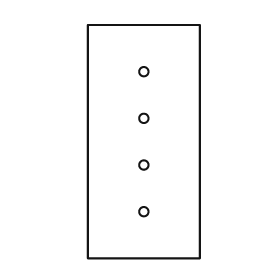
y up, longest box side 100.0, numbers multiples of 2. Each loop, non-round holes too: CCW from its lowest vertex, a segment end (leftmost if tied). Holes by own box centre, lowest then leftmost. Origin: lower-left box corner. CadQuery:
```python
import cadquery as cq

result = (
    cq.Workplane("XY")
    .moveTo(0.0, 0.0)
    .lineTo(48.0, 0.0)
    .lineTo(48.0, 100.0)
    .lineTo(0.0, 100.0)
    .close()
    .moveTo(24.0, 20.0)
    .circle(2.0)
    .moveTo(24.0, 40.0)
    .circle(2.0)
    .moveTo(24.0, 60.0)
    .circle(2.0)
    .moveTo(24.0, 80.0)
    .circle(2.0)
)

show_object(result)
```